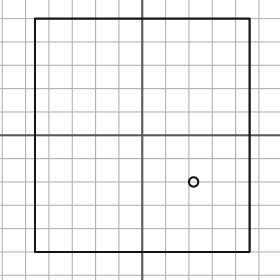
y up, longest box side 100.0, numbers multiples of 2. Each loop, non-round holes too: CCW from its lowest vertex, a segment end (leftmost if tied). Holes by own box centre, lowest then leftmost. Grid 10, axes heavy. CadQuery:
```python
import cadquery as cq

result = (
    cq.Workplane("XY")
    .moveTo(-46.0, -50.0)
    .lineTo(46.0, -50.0)
    .lineTo(46.0, 50.0)
    .lineTo(-46.0, 50.0)
    .close()
    .moveTo(22.0, -20.0)
    .circle(2.0)
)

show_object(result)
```